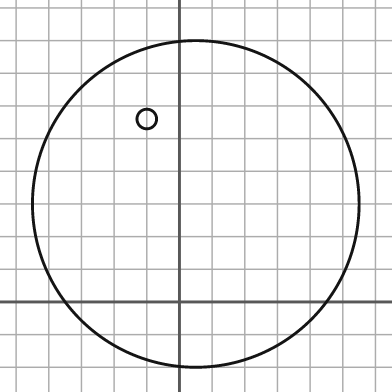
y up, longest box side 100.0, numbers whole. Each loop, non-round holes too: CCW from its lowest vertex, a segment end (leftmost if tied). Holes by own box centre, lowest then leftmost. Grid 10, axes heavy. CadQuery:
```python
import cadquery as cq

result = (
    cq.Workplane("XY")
    .moveTo(5.0, 30.0)
    .circle(50.0)
    .moveTo(-10.0, 56.0)
    .circle(3.0)
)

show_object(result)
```